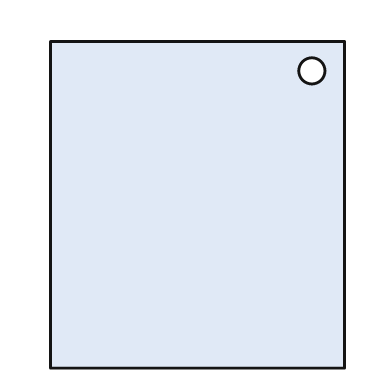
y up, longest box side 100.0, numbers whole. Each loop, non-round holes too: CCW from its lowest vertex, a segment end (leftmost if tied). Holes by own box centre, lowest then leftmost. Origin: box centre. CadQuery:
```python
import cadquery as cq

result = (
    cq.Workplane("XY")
    .moveTo(-45.0, -50.0)
    .lineTo(45.0, -50.0)
    .lineTo(45.0, 50.0)
    .lineTo(-45.0, 50.0)
    .close()
    .moveTo(35.0, 41.0)
    .circle(4.0)
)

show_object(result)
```